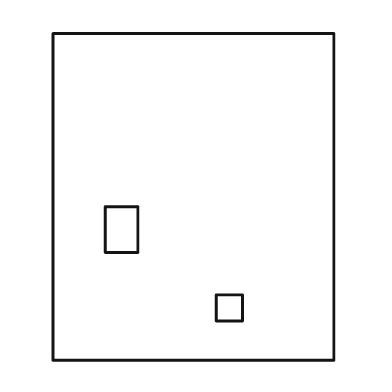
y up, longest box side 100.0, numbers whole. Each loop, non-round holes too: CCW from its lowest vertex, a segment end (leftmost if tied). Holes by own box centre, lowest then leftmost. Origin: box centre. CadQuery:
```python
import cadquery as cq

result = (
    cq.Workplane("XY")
    .moveTo(-43.0, -50.0)
    .lineTo(43.0, -50.0)
    .lineTo(43.0, 50.0)
    .lineTo(-43.0, 50.0)
    .close()
    .moveTo(7.0, -38.0)
    .lineTo(15.0, -38.0)
    .lineTo(15.0, -30.0)
    .lineTo(7.0, -30.0)
    .close()
    .moveTo(-27.0, -17.0)
    .lineTo(-17.0, -17.0)
    .lineTo(-17.0, -3.0)
    .lineTo(-27.0, -3.0)
    .close()
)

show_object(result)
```